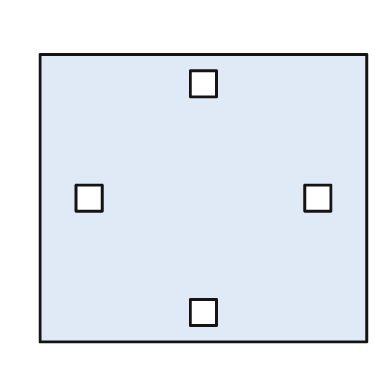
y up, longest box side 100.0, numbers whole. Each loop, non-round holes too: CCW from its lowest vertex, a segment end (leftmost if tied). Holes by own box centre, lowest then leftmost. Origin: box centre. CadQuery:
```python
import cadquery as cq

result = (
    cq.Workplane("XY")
    .moveTo(-50.0, -44.0)
    .lineTo(50.0, -44.0)
    .lineTo(50.0, 44.0)
    .lineTo(-50.0, 44.0)
    .close()
    .moveTo(-4.0, -39.0)
    .lineTo(4.0, -39.0)
    .lineTo(4.0, -31.0)
    .lineTo(-4.0, -31.0)
    .close()
    .moveTo(-39.0, -4.0)
    .lineTo(-31.0, -4.0)
    .lineTo(-31.0, 4.0)
    .lineTo(-39.0, 4.0)
    .close()
    .moveTo(31.0, -4.0)
    .lineTo(39.0, -4.0)
    .lineTo(39.0, 4.0)
    .lineTo(31.0, 4.0)
    .close()
    .moveTo(-4.0, 31.0)
    .lineTo(4.0, 31.0)
    .lineTo(4.0, 39.0)
    .lineTo(-4.0, 39.0)
    .close()
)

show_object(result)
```